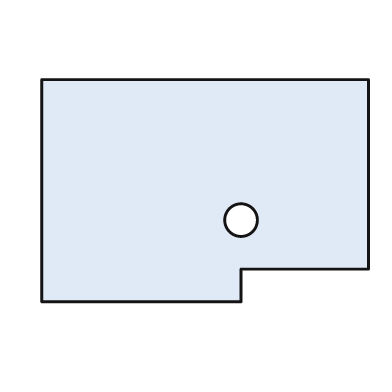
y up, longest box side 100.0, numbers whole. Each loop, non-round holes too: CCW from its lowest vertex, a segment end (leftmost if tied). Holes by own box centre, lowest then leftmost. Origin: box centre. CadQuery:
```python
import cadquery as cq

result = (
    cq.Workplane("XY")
    .moveTo(-50.0, -34.0)
    .lineTo(11.0, -34.0)
    .lineTo(11.0, -24.0)
    .lineTo(50.0, -24.0)
    .lineTo(50.0, 34.0)
    .lineTo(-50.0, 34.0)
    .close()
    .moveTo(11.0, -9.0)
    .circle(5.0)
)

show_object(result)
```